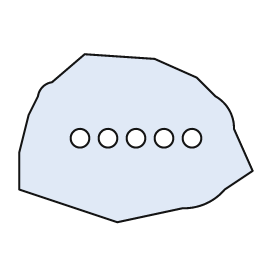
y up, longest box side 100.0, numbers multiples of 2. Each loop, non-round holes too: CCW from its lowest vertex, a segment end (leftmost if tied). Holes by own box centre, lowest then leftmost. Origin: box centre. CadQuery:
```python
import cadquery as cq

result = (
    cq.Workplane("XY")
    .moveTo(-8.0, -36.0)
    .lineTo(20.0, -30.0)
    .threePointArc((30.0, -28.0), (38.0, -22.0))
    .lineTo(50.0, -14.0)
    .lineTo(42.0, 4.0)
    .threePointArc((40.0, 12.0), (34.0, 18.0))
    .lineTo(26.0, 26.0)
    .lineTo(8.0, 34.0)
    .lineTo(-22.0, 36.0)
    .lineTo(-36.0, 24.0)
    .threePointArc((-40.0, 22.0), (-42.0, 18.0))
    .lineTo(-46.0, 10.0)
    .lineTo(-50.0, -6.0)
    .lineTo(-50.0, -22.0)
    .close()
    .moveTo(-24.0, 0.0)
    .circle(4.0)
    .moveTo(-12.0, 0.0)
    .circle(4.0)
    .moveTo(0.0, 0.0)
    .circle(4.0)
    .moveTo(12.0, 0.0)
    .circle(4.0)
    .moveTo(24.0, 0.0)
    .circle(4.0)
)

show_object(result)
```